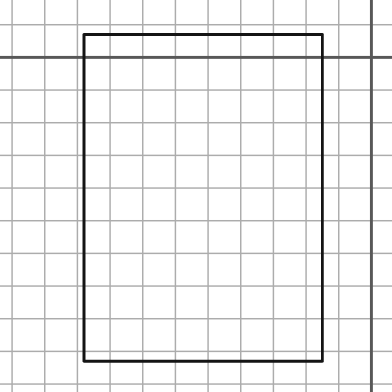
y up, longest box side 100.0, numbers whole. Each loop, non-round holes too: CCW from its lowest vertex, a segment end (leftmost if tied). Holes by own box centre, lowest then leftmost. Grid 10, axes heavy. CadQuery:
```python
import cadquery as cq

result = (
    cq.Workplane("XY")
    .moveTo(-88.0, -93.0)
    .lineTo(-15.0, -93.0)
    .lineTo(-15.0, 7.0)
    .lineTo(-88.0, 7.0)
    .close()
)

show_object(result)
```